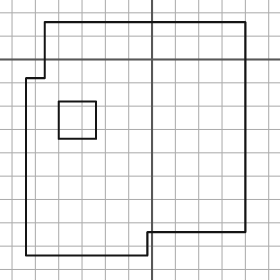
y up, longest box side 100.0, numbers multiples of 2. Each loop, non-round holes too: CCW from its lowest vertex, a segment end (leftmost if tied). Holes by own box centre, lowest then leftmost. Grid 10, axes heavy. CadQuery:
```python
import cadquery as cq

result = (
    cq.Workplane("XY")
    .moveTo(-54.0, -84.0)
    .lineTo(-2.0, -84.0)
    .lineTo(-2.0, -74.0)
    .lineTo(40.0, -74.0)
    .lineTo(40.0, 16.0)
    .lineTo(-46.0, 16.0)
    .lineTo(-46.0, -8.0)
    .lineTo(-54.0, -8.0)
    .close()
    .moveTo(-40.0, -34.0)
    .lineTo(-24.0, -34.0)
    .lineTo(-24.0, -18.0)
    .lineTo(-40.0, -18.0)
    .close()
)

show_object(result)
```